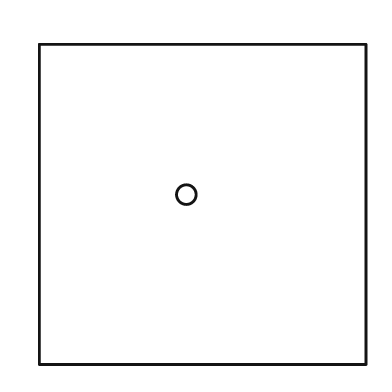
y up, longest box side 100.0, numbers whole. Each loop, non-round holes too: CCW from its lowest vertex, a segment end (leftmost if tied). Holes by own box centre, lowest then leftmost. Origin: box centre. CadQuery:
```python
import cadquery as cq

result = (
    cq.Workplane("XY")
    .moveTo(-50.0, -49.0)
    .lineTo(50.0, -49.0)
    .lineTo(50.0, 49.0)
    .lineTo(-50.0, 49.0)
    .close()
    .moveTo(-5.0, 3.0)
    .circle(3.0)
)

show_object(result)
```